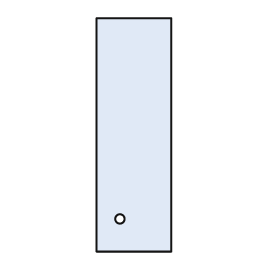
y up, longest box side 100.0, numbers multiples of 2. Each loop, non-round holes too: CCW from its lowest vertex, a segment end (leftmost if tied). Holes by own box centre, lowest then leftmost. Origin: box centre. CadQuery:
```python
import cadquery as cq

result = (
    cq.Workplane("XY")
    .moveTo(-16.0, -50.0)
    .lineTo(16.0, -50.0)
    .lineTo(16.0, 50.0)
    .lineTo(-16.0, 50.0)
    .close()
    .moveTo(-6.0, -36.0)
    .circle(2.0)
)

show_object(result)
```